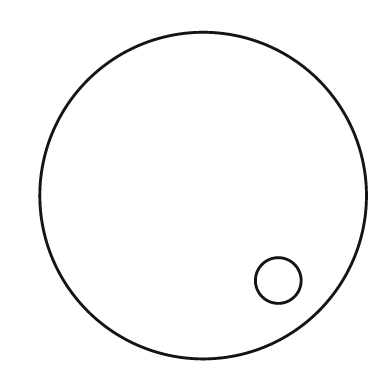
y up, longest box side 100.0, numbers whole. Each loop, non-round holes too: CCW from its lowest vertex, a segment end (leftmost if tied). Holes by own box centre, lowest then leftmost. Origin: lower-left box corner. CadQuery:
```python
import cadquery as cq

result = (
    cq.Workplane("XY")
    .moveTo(50.0, 50.0)
    .circle(50.0)
    .moveTo(73.0, 24.0)
    .circle(7.0)
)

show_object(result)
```